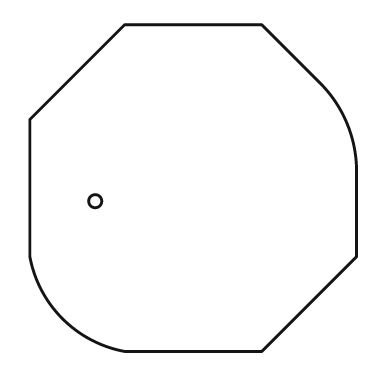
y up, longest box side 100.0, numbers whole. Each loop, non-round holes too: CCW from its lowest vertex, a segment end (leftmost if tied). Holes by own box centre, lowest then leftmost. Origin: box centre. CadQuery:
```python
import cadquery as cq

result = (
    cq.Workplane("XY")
    .moveTo(-21.0, -50.0)
    .lineTo(21.0, -50.0)
    .lineTo(50.0, -21.0)
    .lineTo(50.0, 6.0)
    .threePointArc((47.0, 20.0), (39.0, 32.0))
    .lineTo(21.0, 50.0)
    .lineTo(-21.0, 50.0)
    .lineTo(-50.0, 21.0)
    .lineTo(-50.0, -21.0)
    .threePointArc((-40.0, -40.0), (-21.0, -50.0))
    .close()
    .moveTo(-30.0, -4.0)
    .circle(2.0)
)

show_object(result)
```